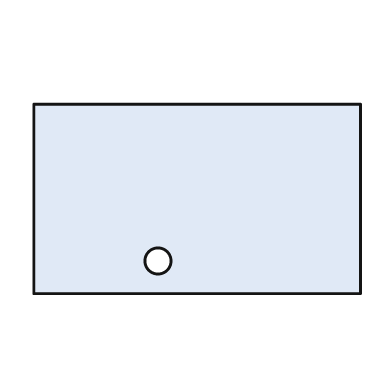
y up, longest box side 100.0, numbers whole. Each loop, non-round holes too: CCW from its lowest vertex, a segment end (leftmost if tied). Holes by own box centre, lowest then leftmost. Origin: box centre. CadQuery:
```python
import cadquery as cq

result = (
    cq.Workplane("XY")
    .moveTo(-50.0, -29.0)
    .lineTo(50.0, -29.0)
    .lineTo(50.0, 29.0)
    .lineTo(-50.0, 29.0)
    .close()
    .moveTo(-12.0, -19.0)
    .circle(4.0)
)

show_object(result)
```